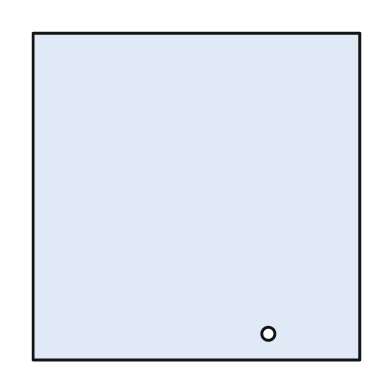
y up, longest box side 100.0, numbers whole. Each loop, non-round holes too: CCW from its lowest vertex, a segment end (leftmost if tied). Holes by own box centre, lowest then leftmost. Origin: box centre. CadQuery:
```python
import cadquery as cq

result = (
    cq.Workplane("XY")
    .moveTo(-50.0, -50.0)
    .lineTo(50.0, -50.0)
    .lineTo(50.0, 50.0)
    .lineTo(-50.0, 50.0)
    .close()
    .moveTo(22.0, -42.0)
    .circle(2.0)
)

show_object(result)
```